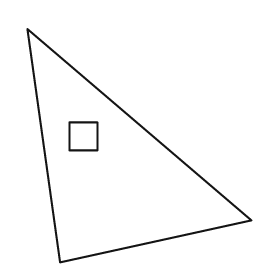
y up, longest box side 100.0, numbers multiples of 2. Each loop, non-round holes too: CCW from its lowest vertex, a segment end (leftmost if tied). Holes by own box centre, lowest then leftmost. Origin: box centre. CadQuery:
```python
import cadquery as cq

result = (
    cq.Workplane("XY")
    .moveTo(-34.0, -50.0)
    .lineTo(48.0, -32.0)
    .lineTo(-48.0, 50.0)
    .close()
    .moveTo(-30.0, -2.0)
    .lineTo(-18.0, -2.0)
    .lineTo(-18.0, 10.0)
    .lineTo(-30.0, 10.0)
    .close()
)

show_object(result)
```